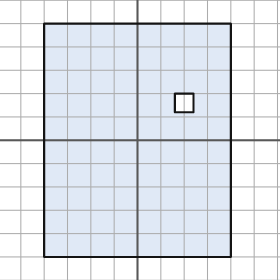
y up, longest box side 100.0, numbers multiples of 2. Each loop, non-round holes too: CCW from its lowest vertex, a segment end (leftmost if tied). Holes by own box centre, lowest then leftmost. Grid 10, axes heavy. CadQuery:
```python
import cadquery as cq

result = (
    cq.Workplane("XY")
    .moveTo(-40.0, -50.0)
    .lineTo(40.0, -50.0)
    .lineTo(40.0, 50.0)
    .lineTo(-40.0, 50.0)
    .close()
    .moveTo(16.0, 12.0)
    .lineTo(24.0, 12.0)
    .lineTo(24.0, 20.0)
    .lineTo(16.0, 20.0)
    .close()
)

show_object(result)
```